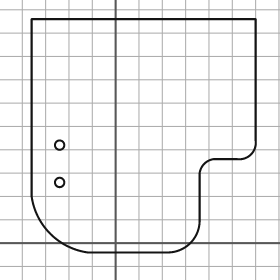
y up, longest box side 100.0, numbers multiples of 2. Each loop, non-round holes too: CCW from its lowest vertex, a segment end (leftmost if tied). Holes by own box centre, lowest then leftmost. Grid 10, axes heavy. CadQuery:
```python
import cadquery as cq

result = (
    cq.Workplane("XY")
    .moveTo(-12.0, -4.0)
    .lineTo(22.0, -4.0)
    .threePointArc((32.0, 0.0), (36.0, 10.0))
    .lineTo(36.0, 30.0)
    .threePointArc((38.0, 34.0), (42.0, 36.0))
    .lineTo(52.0, 36.0)
    .threePointArc((58.0, 38.0), (60.0, 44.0))
    .lineTo(60.0, 96.0)
    .lineTo(-36.0, 96.0)
    .lineTo(-36.0, 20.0)
    .threePointArc((-28.0, 4.0), (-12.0, -4.0))
    .close()
    .moveTo(-24.0, 26.0)
    .circle(2.0)
    .moveTo(-24.0, 42.0)
    .circle(2.0)
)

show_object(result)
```